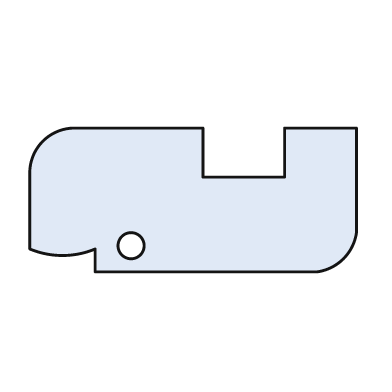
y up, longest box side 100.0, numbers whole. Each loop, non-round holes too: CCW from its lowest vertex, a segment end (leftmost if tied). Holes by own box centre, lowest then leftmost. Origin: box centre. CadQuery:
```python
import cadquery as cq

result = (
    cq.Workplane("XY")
    .moveTo(-30.0, -22.0)
    .lineTo(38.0, -22.0)
    .threePointArc((46.0, -18.0), (50.0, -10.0))
    .lineTo(50.0, 22.0)
    .lineTo(28.0, 22.0)
    .lineTo(28.0, 7.0)
    .lineTo(3.0, 7.0)
    .lineTo(3.0, 22.0)
    .lineTo(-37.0, 22.0)
    .threePointArc((-46.0, 18.0), (-50.0, 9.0))
    .lineTo(-50.0, -15.0)
    .threePointArc((-40.0, -17.0), (-30.0, -15.0))
    .close()
    .moveTo(-19.0, -14.0)
    .circle(4.0)
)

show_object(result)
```